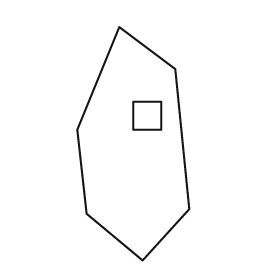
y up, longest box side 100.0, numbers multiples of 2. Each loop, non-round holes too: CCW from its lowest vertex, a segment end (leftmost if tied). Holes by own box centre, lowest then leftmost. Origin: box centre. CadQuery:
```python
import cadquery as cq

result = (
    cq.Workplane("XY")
    .moveTo(4.0, -50.0)
    .lineTo(24.0, -28.0)
    .lineTo(18.0, 32.0)
    .lineTo(-6.0, 50.0)
    .lineTo(-24.0, 6.0)
    .lineTo(-20.0, -30.0)
    .close()
    .moveTo(0.0, 6.0)
    .lineTo(12.0, 6.0)
    .lineTo(12.0, 18.0)
    .lineTo(0.0, 18.0)
    .close()
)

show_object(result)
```